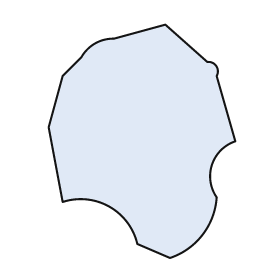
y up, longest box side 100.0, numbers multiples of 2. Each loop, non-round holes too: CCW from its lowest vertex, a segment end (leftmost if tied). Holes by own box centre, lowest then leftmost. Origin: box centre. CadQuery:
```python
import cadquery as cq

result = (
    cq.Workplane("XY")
    .moveTo(12.0, -50.0)
    .threePointArc((26.0, -40.0), (32.0, -24.0))
    .threePointArc((30.0, -10.0), (40.0, 0.0))
    .lineTo(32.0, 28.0)
    .threePointArc((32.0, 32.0), (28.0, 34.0))
    .lineTo(10.0, 50.0)
    .lineTo(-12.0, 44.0)
    .threePointArc((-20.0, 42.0), (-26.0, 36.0))
    .lineTo(-34.0, 28.0)
    .lineTo(-40.0, 6.0)
    .lineTo(-34.0, -26.0)
    .threePointArc((-14.0, -28.0), (-2.0, -44.0))
    .close()
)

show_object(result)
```